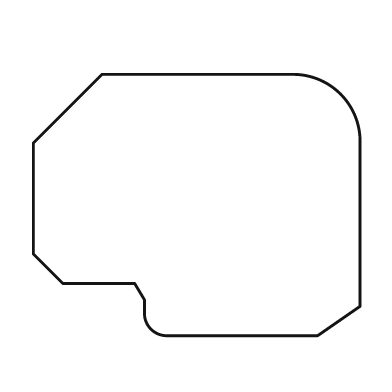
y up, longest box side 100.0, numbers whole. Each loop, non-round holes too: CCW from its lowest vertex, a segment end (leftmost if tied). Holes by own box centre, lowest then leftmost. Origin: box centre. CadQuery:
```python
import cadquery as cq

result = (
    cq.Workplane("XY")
    .moveTo(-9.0, -40.0)
    .lineTo(37.0, -40.0)
    .lineTo(50.0, -31.0)
    .lineTo(50.0, 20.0)
    .threePointArc((44.0, 34.0), (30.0, 40.0))
    .lineTo(-29.0, 40.0)
    .lineTo(-50.0, 19.0)
    .lineTo(-50.0, -15.0)
    .lineTo(-41.0, -24.0)
    .lineTo(-19.0, -24.0)
    .lineTo(-16.0, -29.0)
    .lineTo(-16.0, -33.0)
    .threePointArc((-14.0, -38.0), (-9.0, -40.0))
    .close()
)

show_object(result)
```